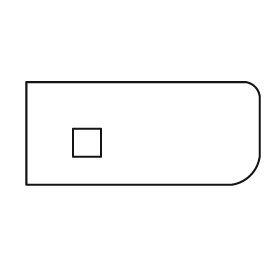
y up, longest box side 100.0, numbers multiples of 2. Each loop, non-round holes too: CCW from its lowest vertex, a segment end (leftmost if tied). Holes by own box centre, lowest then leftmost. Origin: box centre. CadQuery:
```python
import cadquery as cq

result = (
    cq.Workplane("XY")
    .moveTo(-50.0, -22.0)
    .lineTo(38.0, -22.0)
    .threePointArc((46.0, -18.0), (50.0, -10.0))
    .lineTo(50.0, 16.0)
    .threePointArc((48.0, 20.0), (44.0, 22.0))
    .lineTo(-50.0, 22.0)
    .close()
    .moveTo(-30.0, -10.0)
    .lineTo(-18.0, -10.0)
    .lineTo(-18.0, 2.0)
    .lineTo(-30.0, 2.0)
    .close()
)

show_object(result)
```